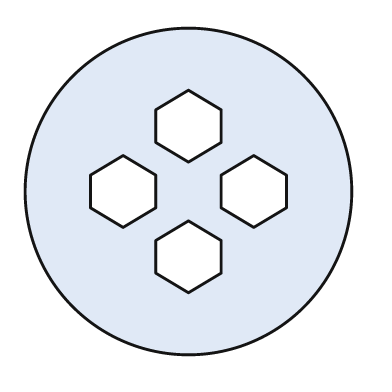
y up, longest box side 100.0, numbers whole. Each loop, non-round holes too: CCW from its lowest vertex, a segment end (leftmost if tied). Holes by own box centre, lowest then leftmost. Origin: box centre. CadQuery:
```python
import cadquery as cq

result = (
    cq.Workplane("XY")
    .moveTo(0.0, 0.0)
    .circle(50.0)
    .moveTo(0.0, -31.0)
    .lineTo(10.0, -25.0)
    .lineTo(10.0, -15.0)
    .lineTo(0.0, -9.0)
    .lineTo(-10.0, -15.0)
    .lineTo(-10.0, -25.0)
    .close()
    .moveTo(-20.0, -11.0)
    .lineTo(-10.0, -5.0)
    .lineTo(-10.0, 5.0)
    .lineTo(-20.0, 11.0)
    .lineTo(-30.0, 5.0)
    .lineTo(-30.0, -5.0)
    .close()
    .moveTo(20.0, -11.0)
    .lineTo(30.0, -5.0)
    .lineTo(30.0, 5.0)
    .lineTo(20.0, 11.0)
    .lineTo(10.0, 5.0)
    .lineTo(10.0, -5.0)
    .close()
    .moveTo(0.0, 9.0)
    .lineTo(10.0, 15.0)
    .lineTo(10.0, 25.0)
    .lineTo(0.0, 31.0)
    .lineTo(-10.0, 25.0)
    .lineTo(-10.0, 15.0)
    .close()
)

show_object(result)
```